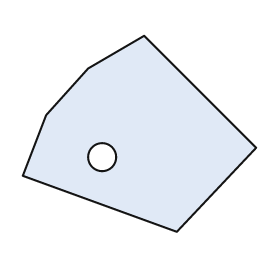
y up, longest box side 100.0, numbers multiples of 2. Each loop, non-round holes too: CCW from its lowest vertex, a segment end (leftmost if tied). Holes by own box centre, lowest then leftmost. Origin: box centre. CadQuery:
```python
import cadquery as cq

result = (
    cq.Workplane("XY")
    .moveTo(16.0, -42.0)
    .lineTo(50.0, -6.0)
    .lineTo(2.0, 42.0)
    .lineTo(-22.0, 28.0)
    .lineTo(-40.0, 8.0)
    .lineTo(-50.0, -18.0)
    .close()
    .moveTo(-16.0, -10.0)
    .circle(6.0)
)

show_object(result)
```